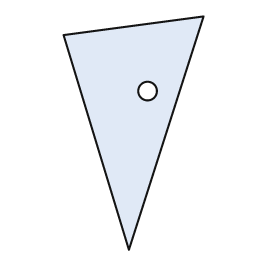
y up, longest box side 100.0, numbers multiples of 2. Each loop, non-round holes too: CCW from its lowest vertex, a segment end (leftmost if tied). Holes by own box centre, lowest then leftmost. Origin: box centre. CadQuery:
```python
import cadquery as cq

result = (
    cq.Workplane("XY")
    .moveTo(-2.0, -50.0)
    .lineTo(30.0, 50.0)
    .lineTo(-30.0, 42.0)
    .close()
    .moveTo(6.0, 18.0)
    .circle(4.0)
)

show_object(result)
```